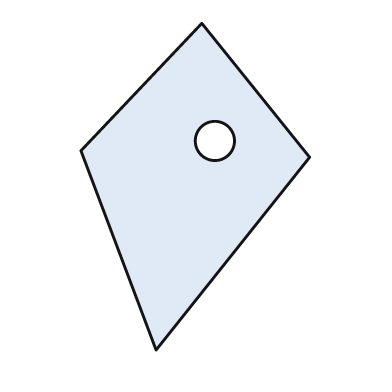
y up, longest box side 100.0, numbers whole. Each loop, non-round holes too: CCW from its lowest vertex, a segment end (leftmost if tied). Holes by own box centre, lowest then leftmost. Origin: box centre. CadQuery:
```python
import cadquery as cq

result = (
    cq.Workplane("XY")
    .moveTo(-12.0, -50.0)
    .lineTo(35.0, 9.0)
    .lineTo(2.0, 50.0)
    .lineTo(-35.0, 11.0)
    .close()
    .moveTo(6.0, 14.0)
    .circle(6.0)
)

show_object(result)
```